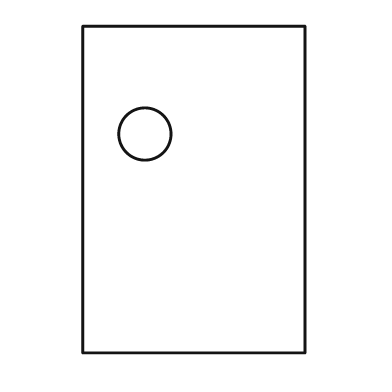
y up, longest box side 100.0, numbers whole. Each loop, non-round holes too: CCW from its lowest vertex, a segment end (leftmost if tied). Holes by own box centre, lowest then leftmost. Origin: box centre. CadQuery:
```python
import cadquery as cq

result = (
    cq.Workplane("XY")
    .moveTo(-34.0, -50.0)
    .lineTo(34.0, -50.0)
    .lineTo(34.0, 50.0)
    .lineTo(-34.0, 50.0)
    .close()
    .moveTo(-15.0, 17.0)
    .circle(8.0)
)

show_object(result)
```